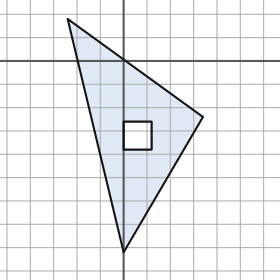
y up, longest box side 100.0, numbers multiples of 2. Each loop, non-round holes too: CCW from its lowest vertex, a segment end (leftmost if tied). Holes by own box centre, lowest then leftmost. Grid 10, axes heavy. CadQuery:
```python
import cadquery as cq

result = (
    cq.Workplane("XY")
    .moveTo(0.0, -82.0)
    .lineTo(34.0, -24.0)
    .lineTo(-24.0, 18.0)
    .close()
    .moveTo(0.0, -38.0)
    .lineTo(12.0, -38.0)
    .lineTo(12.0, -26.0)
    .lineTo(0.0, -26.0)
    .close()
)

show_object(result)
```